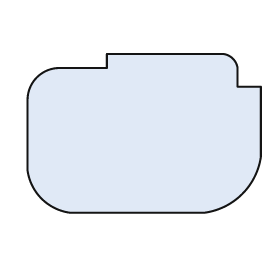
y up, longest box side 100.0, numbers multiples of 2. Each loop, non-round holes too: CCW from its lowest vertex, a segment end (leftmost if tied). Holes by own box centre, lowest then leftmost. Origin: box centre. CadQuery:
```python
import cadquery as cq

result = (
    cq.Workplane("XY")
    .moveTo(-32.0, -34.0)
    .lineTo(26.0, -34.0)
    .threePointArc((42.0, -26.0), (50.0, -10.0))
    .lineTo(50.0, 20.0)
    .lineTo(40.0, 20.0)
    .lineTo(40.0, 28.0)
    .threePointArc((38.0, 32.0), (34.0, 34.0))
    .lineTo(-16.0, 34.0)
    .lineTo(-16.0, 28.0)
    .lineTo(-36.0, 28.0)
    .threePointArc((-46.0, 24.0), (-50.0, 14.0))
    .lineTo(-50.0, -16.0)
    .threePointArc((-44.0, -28.0), (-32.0, -34.0))
    .close()
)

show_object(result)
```